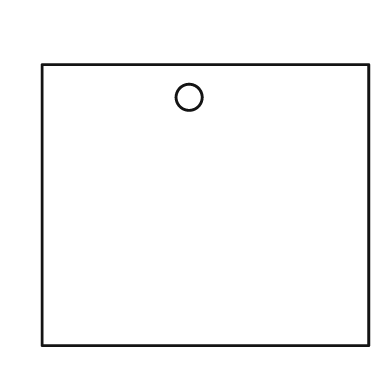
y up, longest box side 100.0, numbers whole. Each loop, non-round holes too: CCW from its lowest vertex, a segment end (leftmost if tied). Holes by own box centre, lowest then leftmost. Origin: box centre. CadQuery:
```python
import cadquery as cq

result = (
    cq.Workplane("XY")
    .moveTo(-50.0, -43.0)
    .lineTo(50.0, -43.0)
    .lineTo(50.0, 43.0)
    .lineTo(-50.0, 43.0)
    .close()
    .moveTo(-5.0, 33.0)
    .circle(4.0)
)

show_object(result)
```